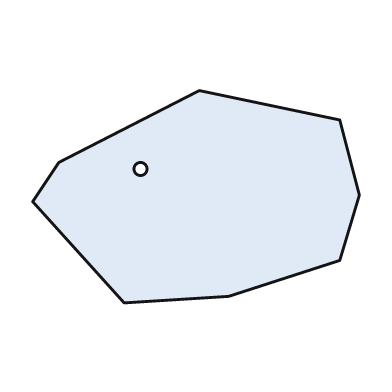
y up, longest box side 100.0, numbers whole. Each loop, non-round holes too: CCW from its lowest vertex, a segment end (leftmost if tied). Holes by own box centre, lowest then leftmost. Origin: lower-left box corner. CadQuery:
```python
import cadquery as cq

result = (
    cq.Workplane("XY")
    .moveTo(28.0, 0.0)
    .lineTo(60.0, 2.0)
    .lineTo(94.0, 13.0)
    .lineTo(100.0, 33.0)
    .lineTo(94.0, 56.0)
    .lineTo(51.0, 65.0)
    .lineTo(8.0, 43.0)
    .lineTo(0.0, 31.0)
    .close()
    .moveTo(33.0, 41.0)
    .circle(2.0)
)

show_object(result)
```